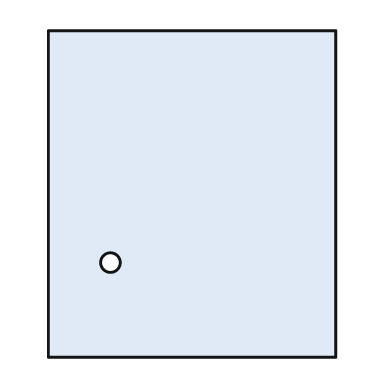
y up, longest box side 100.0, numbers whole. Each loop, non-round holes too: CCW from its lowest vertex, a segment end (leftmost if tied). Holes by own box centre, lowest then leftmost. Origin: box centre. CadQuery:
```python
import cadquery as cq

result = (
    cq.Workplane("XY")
    .moveTo(-44.0, -50.0)
    .lineTo(44.0, -50.0)
    .lineTo(44.0, 50.0)
    .lineTo(-44.0, 50.0)
    .close()
    .moveTo(-25.0, -21.0)
    .circle(3.0)
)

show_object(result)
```